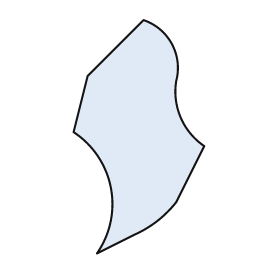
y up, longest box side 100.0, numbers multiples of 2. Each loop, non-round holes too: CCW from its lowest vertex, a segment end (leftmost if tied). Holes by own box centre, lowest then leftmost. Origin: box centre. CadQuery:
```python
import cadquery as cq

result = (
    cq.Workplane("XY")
    .moveTo(-18.0, -50.0)
    .lineTo(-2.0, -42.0)
    .threePointArc((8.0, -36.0), (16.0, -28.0))
    .lineTo(28.0, -4.0)
    .threePointArc((18.0, 8.0), (16.0, 24.0))
    .threePointArc((14.0, 40.0), (2.0, 50.0))
    .lineTo(-22.0, 26.0)
    .lineTo(-28.0, 2.0)
    .threePointArc((-12.0, -22.0), (-18.0, -50.0))
    .close()
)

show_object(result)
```